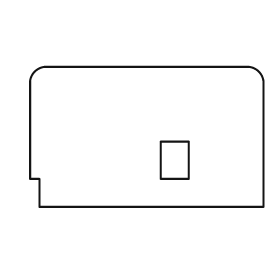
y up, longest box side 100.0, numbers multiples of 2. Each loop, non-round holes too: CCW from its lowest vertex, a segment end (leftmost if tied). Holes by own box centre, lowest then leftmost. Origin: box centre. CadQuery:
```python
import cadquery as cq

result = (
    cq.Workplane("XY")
    .moveTo(-46.0, -30.0)
    .lineTo(50.0, -30.0)
    .lineTo(50.0, 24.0)
    .threePointArc((48.0, 28.0), (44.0, 30.0))
    .lineTo(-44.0, 30.0)
    .threePointArc((-48.0, 28.0), (-50.0, 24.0))
    .lineTo(-50.0, -18.0)
    .lineTo(-46.0, -18.0)
    .close()
    .moveTo(6.0, -18.0)
    .lineTo(18.0, -18.0)
    .lineTo(18.0, -2.0)
    .lineTo(6.0, -2.0)
    .close()
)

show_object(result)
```